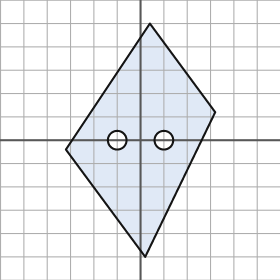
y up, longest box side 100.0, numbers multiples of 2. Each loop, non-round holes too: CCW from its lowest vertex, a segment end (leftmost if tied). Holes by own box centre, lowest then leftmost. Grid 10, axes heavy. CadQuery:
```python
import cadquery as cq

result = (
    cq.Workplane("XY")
    .moveTo(2.0, -50.0)
    .lineTo(32.0, 12.0)
    .lineTo(4.0, 50.0)
    .lineTo(-32.0, -4.0)
    .close()
    .moveTo(-10.0, 0.0)
    .circle(4.0)
    .moveTo(10.0, 0.0)
    .circle(4.0)
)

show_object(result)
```